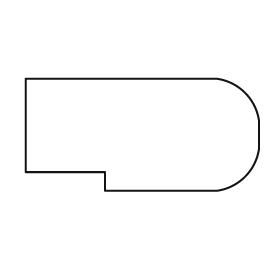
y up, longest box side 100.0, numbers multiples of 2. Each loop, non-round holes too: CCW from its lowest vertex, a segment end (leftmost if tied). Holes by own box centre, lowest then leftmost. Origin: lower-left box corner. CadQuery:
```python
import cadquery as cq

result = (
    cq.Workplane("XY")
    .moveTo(34.0, 0.0)
    .lineTo(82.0, 0.0)
    .threePointArc((94.0, 6.0), (100.0, 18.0))
    .lineTo(100.0, 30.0)
    .threePointArc((94.0, 42.0), (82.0, 48.0))
    .lineTo(0.0, 48.0)
    .lineTo(0.0, 8.0)
    .lineTo(34.0, 8.0)
    .close()
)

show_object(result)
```